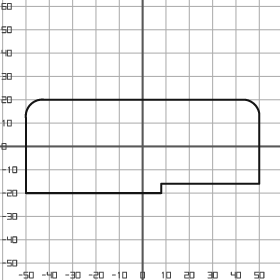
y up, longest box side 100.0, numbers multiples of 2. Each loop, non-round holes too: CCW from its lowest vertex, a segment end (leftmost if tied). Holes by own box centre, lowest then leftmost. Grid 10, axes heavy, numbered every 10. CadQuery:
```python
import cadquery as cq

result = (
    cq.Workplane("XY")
    .moveTo(-50.0, -20.0)
    .lineTo(8.0, -20.0)
    .lineTo(8.0, -16.0)
    .lineTo(50.0, -16.0)
    .lineTo(50.0, 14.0)
    .threePointArc((48.0, 18.0), (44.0, 20.0))
    .lineTo(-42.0, 20.0)
    .threePointArc((-48.0, 18.0), (-50.0, 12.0))
    .close()
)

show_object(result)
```